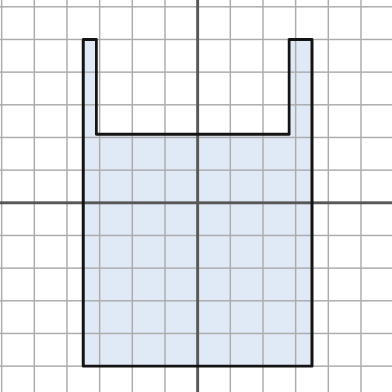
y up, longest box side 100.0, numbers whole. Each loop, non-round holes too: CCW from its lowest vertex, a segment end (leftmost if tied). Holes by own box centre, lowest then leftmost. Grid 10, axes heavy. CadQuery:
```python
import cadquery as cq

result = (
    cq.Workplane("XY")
    .moveTo(-35.0, -50.0)
    .lineTo(35.0, -50.0)
    .lineTo(35.0, 50.0)
    .lineTo(28.0, 50.0)
    .lineTo(28.0, 21.0)
    .lineTo(-31.0, 21.0)
    .lineTo(-31.0, 50.0)
    .lineTo(-35.0, 50.0)
    .close()
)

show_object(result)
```